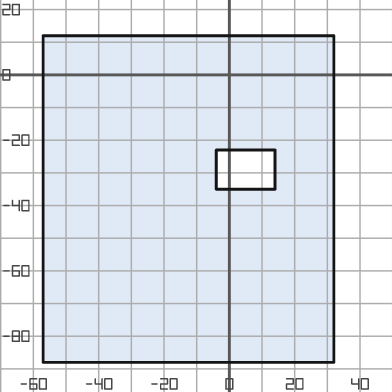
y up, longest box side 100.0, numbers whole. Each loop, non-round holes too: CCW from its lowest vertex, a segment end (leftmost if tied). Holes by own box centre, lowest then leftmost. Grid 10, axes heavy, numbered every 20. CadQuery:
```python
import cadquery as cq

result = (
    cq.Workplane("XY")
    .moveTo(-57.0, -88.0)
    .lineTo(32.0, -88.0)
    .lineTo(32.0, 12.0)
    .lineTo(-57.0, 12.0)
    .close()
    .moveTo(-4.0, -35.0)
    .lineTo(14.0, -35.0)
    .lineTo(14.0, -23.0)
    .lineTo(-4.0, -23.0)
    .close()
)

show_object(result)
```